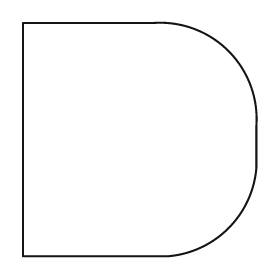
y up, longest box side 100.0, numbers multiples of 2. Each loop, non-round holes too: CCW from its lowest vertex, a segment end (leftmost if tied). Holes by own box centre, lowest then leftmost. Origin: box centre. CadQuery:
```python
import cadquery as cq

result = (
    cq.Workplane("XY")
    .moveTo(-50.0, -50.0)
    .lineTo(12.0, -50.0)
    .threePointArc((38.0, -38.0), (50.0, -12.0))
    .lineTo(50.0, 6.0)
    .threePointArc((38.0, 38.0), (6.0, 50.0))
    .lineTo(-50.0, 50.0)
    .close()
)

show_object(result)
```